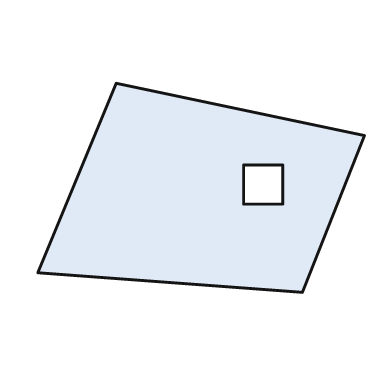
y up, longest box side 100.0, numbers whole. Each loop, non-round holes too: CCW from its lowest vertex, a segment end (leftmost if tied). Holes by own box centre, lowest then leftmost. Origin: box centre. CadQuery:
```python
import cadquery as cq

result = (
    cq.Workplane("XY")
    .moveTo(31.0, -32.0)
    .lineTo(50.0, 16.0)
    .lineTo(-26.0, 32.0)
    .lineTo(-50.0, -26.0)
    .close()
    .moveTo(13.0, -5.0)
    .lineTo(25.0, -5.0)
    .lineTo(25.0, 7.0)
    .lineTo(13.0, 7.0)
    .close()
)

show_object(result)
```